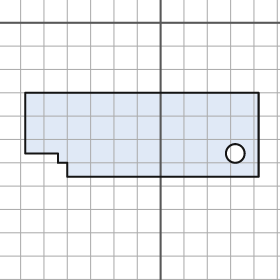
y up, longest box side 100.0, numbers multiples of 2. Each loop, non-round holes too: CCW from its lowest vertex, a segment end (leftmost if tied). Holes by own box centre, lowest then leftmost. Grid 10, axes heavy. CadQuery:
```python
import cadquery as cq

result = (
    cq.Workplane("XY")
    .moveTo(-40.0, -66.0)
    .lineTo(42.0, -66.0)
    .lineTo(42.0, -30.0)
    .lineTo(-58.0, -30.0)
    .lineTo(-58.0, -56.0)
    .lineTo(-44.0, -56.0)
    .lineTo(-44.0, -60.0)
    .lineTo(-40.0, -60.0)
    .close()
    .moveTo(32.0, -56.0)
    .circle(4.0)
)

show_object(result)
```